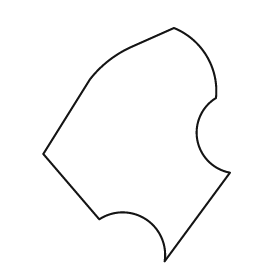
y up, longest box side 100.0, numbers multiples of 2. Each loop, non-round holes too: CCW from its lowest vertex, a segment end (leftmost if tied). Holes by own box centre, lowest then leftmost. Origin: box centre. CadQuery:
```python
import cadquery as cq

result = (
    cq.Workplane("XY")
    .moveTo(12.0, -50.0)
    .lineTo(40.0, -12.0)
    .threePointArc((26.0, 2.0), (34.0, 20.0))
    .threePointArc((30.0, 38.0), (16.0, 50.0))
    .lineTo(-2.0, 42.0)
    .threePointArc((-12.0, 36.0), (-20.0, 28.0))
    .lineTo(-40.0, -4.0)
    .lineTo(-16.0, -32.0)
    .threePointArc((4.0, -32.0), (12.0, -50.0))
    .close()
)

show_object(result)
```